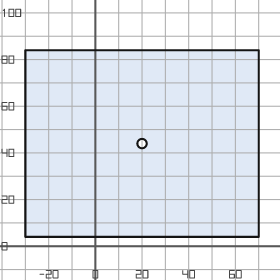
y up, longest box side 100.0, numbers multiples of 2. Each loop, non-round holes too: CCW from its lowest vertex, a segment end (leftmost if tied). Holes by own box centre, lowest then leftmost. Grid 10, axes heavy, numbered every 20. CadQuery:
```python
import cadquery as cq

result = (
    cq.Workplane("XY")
    .moveTo(-30.0, 4.0)
    .lineTo(70.0, 4.0)
    .lineTo(70.0, 84.0)
    .lineTo(-30.0, 84.0)
    .close()
    .moveTo(20.0, 44.0)
    .circle(2.0)
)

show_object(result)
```